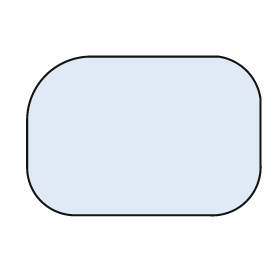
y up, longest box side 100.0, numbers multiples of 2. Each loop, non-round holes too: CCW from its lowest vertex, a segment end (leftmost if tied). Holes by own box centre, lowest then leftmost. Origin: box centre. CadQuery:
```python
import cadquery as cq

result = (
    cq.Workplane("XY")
    .moveTo(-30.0, -34.0)
    .lineTo(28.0, -34.0)
    .threePointArc((44.0, -28.0), (50.0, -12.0))
    .lineTo(50.0, 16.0)
    .threePointArc((44.0, 28.0), (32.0, 34.0))
    .lineTo(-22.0, 34.0)
    .threePointArc((-42.0, 26.0), (-50.0, 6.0))
    .lineTo(-50.0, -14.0)
    .threePointArc((-44.0, -28.0), (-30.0, -34.0))
    .close()
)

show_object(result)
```